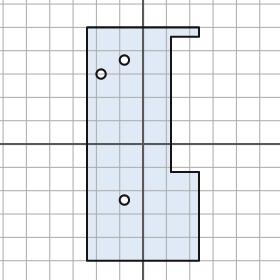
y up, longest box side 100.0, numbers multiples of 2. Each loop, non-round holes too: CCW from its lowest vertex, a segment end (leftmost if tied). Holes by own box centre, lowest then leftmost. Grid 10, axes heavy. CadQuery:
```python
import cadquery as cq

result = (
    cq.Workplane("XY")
    .moveTo(-24.0, -50.0)
    .lineTo(24.0, -50.0)
    .lineTo(24.0, -12.0)
    .lineTo(12.0, -12.0)
    .lineTo(12.0, 46.0)
    .lineTo(24.0, 46.0)
    .lineTo(24.0, 50.0)
    .lineTo(-24.0, 50.0)
    .close()
    .moveTo(-8.0, -24.0)
    .circle(2.0)
    .moveTo(-18.0, 30.0)
    .circle(2.0)
    .moveTo(-8.0, 36.0)
    .circle(2.0)
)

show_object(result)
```